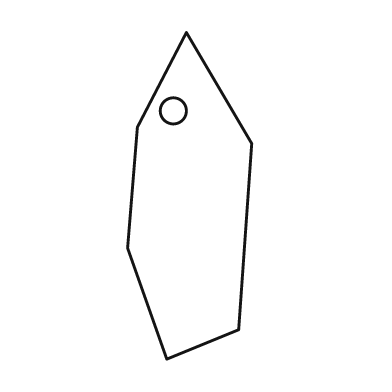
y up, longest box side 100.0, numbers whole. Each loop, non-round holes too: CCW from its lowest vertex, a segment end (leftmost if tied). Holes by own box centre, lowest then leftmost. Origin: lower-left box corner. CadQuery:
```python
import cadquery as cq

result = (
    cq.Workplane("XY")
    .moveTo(12.0, 0.0)
    .lineTo(34.0, 9.0)
    .lineTo(38.0, 66.0)
    .lineTo(18.0, 100.0)
    .lineTo(3.0, 71.0)
    .lineTo(0.0, 34.0)
    .close()
    .moveTo(14.0, 76.0)
    .circle(4.0)
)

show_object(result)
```